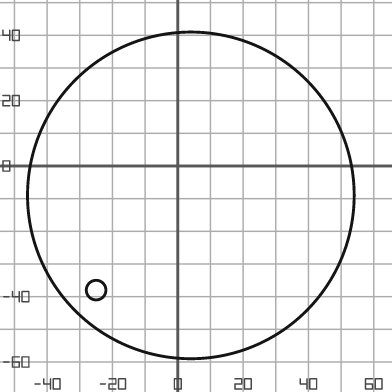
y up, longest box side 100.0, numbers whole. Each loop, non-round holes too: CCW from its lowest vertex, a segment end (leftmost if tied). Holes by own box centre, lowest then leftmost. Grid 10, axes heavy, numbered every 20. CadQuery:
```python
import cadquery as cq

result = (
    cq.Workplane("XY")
    .moveTo(4.0, -9.0)
    .circle(50.0)
    .moveTo(-25.0, -38.0)
    .circle(3.0)
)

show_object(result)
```